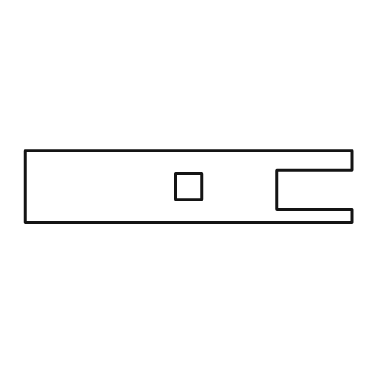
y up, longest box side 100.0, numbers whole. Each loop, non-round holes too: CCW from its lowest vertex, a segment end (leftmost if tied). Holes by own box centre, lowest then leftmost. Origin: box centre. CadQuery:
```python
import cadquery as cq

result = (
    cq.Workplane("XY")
    .moveTo(-50.0, -11.0)
    .lineTo(50.0, -11.0)
    .lineTo(50.0, -7.0)
    .lineTo(27.0, -7.0)
    .lineTo(27.0, 5.0)
    .lineTo(50.0, 5.0)
    .lineTo(50.0, 11.0)
    .lineTo(-50.0, 11.0)
    .close()
    .moveTo(-4.0, -4.0)
    .lineTo(4.0, -4.0)
    .lineTo(4.0, 4.0)
    .lineTo(-4.0, 4.0)
    .close()
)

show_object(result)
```